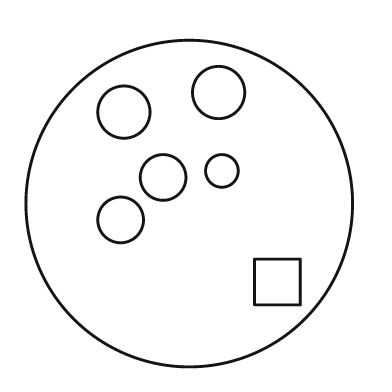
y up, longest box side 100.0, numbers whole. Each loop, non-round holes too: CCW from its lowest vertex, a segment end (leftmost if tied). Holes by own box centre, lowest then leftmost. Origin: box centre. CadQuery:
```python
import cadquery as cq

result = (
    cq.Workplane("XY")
    .moveTo(0.0, 0.0)
    .circle(50.0)
    .moveTo(20.0, -31.0)
    .lineTo(34.0, -31.0)
    .lineTo(34.0, -17.0)
    .lineTo(20.0, -17.0)
    .close()
    .moveTo(-21.0, -5.0)
    .circle(7.0)
    .moveTo(-8.0, 8.0)
    .circle(7.0)
    .moveTo(10.0, 10.0)
    .circle(5.0)
    .moveTo(-20.0, 28.0)
    .circle(8.0)
    .moveTo(9.0, 34.0)
    .circle(8.0)
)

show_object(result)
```